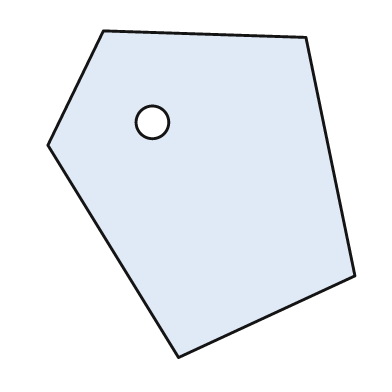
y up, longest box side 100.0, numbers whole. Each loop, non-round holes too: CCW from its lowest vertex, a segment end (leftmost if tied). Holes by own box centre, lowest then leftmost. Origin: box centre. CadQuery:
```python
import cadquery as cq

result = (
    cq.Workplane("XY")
    .moveTo(-7.0, -50.0)
    .lineTo(47.0, -25.0)
    .lineTo(32.0, 48.0)
    .lineTo(-30.0, 50.0)
    .lineTo(-47.0, 15.0)
    .close()
    .moveTo(-15.0, 22.0)
    .circle(5.0)
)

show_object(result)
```